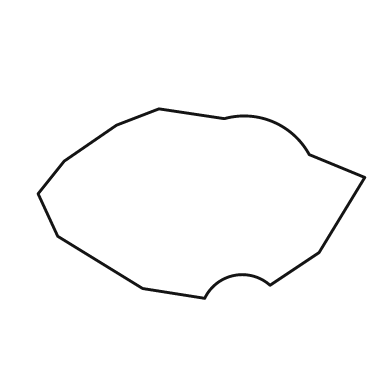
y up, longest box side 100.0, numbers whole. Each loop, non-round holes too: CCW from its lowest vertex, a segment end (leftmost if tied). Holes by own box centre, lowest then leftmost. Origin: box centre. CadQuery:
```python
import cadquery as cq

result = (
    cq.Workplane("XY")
    .moveTo(1.0, -29.0)
    .threePointArc((10.0, -22.0), (21.0, -25.0))
    .lineTo(36.0, -15.0)
    .lineTo(50.0, 8.0)
    .lineTo(33.0, 15.0)
    .threePointArc((22.0, 25.0), (7.0, 26.0))
    .lineTo(-13.0, 29.0)
    .lineTo(-26.0, 24.0)
    .lineTo(-42.0, 13.0)
    .lineTo(-50.0, 3.0)
    .lineTo(-44.0, -10.0)
    .lineTo(-18.0, -26.0)
    .close()
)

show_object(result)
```